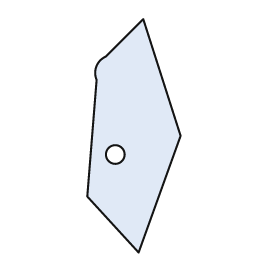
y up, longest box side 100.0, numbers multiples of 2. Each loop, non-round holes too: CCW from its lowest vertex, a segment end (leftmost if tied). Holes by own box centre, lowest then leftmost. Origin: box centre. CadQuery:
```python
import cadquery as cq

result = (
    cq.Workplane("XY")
    .moveTo(2.0, -50.0)
    .lineTo(20.0, 0.0)
    .lineTo(4.0, 50.0)
    .lineTo(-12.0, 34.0)
    .threePointArc((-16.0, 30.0), (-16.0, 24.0))
    .lineTo(-20.0, -26.0)
    .close()
    .moveTo(-8.0, -8.0)
    .circle(4.0)
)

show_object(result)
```